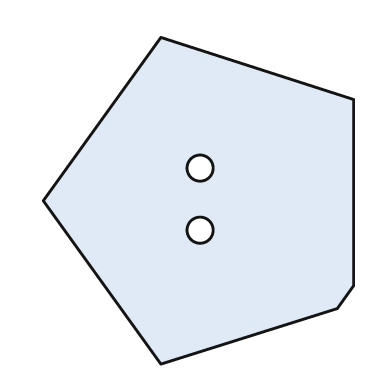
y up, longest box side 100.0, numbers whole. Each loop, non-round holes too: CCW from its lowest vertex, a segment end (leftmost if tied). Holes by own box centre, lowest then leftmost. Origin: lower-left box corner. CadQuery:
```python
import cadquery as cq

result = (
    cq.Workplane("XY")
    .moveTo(36.0, 0.0)
    .lineTo(90.0, 17.0)
    .lineTo(95.0, 24.0)
    .lineTo(95.0, 81.0)
    .lineTo(36.0, 100.0)
    .lineTo(0.0, 50.0)
    .close()
    .moveTo(48.0, 41.0)
    .circle(4.0)
    .moveTo(48.0, 60.0)
    .circle(4.0)
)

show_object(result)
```